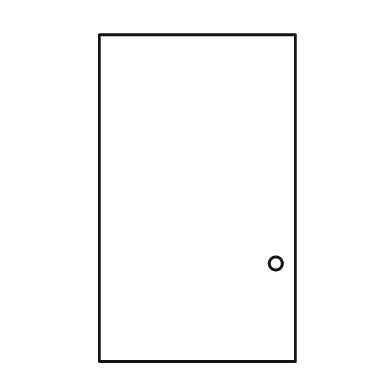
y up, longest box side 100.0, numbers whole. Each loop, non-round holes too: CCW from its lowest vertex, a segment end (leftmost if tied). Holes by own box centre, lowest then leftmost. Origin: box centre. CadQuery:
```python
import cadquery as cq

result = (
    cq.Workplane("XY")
    .moveTo(-30.0, -50.0)
    .lineTo(30.0, -50.0)
    .lineTo(30.0, 50.0)
    .lineTo(-30.0, 50.0)
    .close()
    .moveTo(24.0, -20.0)
    .circle(2.0)
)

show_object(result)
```